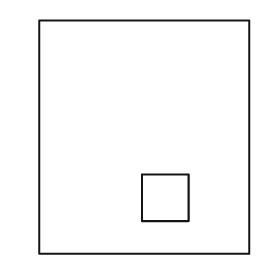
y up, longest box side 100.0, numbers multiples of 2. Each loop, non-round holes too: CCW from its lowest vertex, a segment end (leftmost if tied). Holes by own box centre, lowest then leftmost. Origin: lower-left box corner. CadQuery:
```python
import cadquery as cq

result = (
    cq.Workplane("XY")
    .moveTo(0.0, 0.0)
    .lineTo(90.0, 0.0)
    .lineTo(90.0, 100.0)
    .lineTo(0.0, 100.0)
    .close()
    .moveTo(44.0, 14.0)
    .lineTo(64.0, 14.0)
    .lineTo(64.0, 34.0)
    .lineTo(44.0, 34.0)
    .close()
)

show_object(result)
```